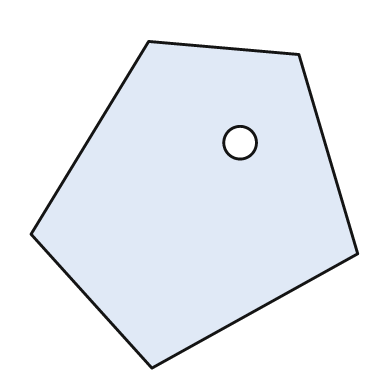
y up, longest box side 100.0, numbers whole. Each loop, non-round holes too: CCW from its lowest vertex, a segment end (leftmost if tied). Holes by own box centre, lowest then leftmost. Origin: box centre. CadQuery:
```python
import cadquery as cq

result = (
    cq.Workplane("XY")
    .moveTo(-13.0, -50.0)
    .lineTo(50.0, -15.0)
    .lineTo(32.0, 46.0)
    .lineTo(-14.0, 50.0)
    .lineTo(-50.0, -9.0)
    .close()
    .moveTo(14.0, 19.0)
    .circle(5.0)
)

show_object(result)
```